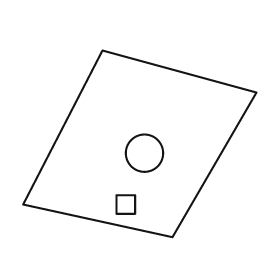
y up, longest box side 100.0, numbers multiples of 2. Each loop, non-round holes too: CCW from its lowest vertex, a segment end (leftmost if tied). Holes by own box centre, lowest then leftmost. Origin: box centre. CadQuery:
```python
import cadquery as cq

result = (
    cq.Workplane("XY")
    .moveTo(14.0, -40.0)
    .lineTo(50.0, 22.0)
    .lineTo(-16.0, 40.0)
    .lineTo(-50.0, -26.0)
    .close()
    .moveTo(-10.0, -30.0)
    .lineTo(-2.0, -30.0)
    .lineTo(-2.0, -22.0)
    .lineTo(-10.0, -22.0)
    .close()
    .moveTo(2.0, -4.0)
    .circle(8.0)
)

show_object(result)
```